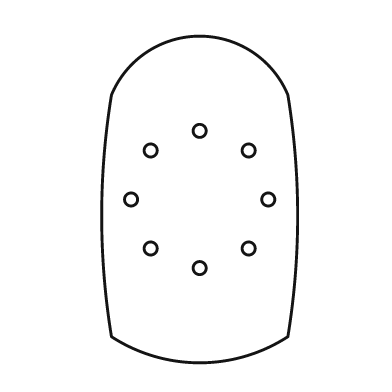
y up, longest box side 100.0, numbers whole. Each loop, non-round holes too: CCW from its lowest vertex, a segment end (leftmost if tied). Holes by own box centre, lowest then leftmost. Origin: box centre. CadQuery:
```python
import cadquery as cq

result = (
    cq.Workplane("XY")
    .moveTo(-27.0, -42.0)
    .threePointArc((0.0, -50.0), (27.0, -42.0))
    .threePointArc((30.0, -5.0), (27.0, 32.0))
    .threePointArc((0.0, 50.0), (-27.0, 32.0))
    .threePointArc((-30.0, -5.0), (-27.0, -42.0))
    .close()
    .moveTo(0.0, -21.0)
    .circle(2.0)
    .moveTo(-15.0, -15.0)
    .circle(2.0)
    .moveTo(15.0, -15.0)
    .circle(2.0)
    .moveTo(-21.0, 0.0)
    .circle(2.0)
    .moveTo(21.0, 0.0)
    .circle(2.0)
    .moveTo(-15.0, 15.0)
    .circle(2.0)
    .moveTo(15.0, 15.0)
    .circle(2.0)
    .moveTo(0.0, 21.0)
    .circle(2.0)
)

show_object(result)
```